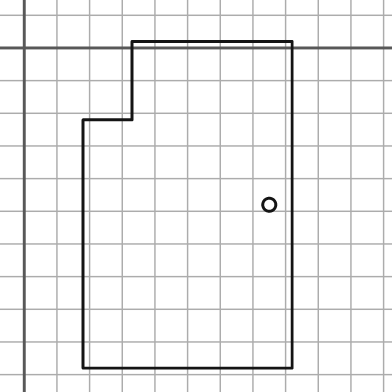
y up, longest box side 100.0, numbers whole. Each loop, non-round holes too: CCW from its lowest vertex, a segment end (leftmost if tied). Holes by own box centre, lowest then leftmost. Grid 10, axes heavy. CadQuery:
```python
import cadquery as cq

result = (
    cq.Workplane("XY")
    .moveTo(18.0, -98.0)
    .lineTo(82.0, -98.0)
    .lineTo(82.0, 2.0)
    .lineTo(33.0, 2.0)
    .lineTo(33.0, -22.0)
    .lineTo(18.0, -22.0)
    .close()
    .moveTo(75.0, -48.0)
    .circle(2.0)
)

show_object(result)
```